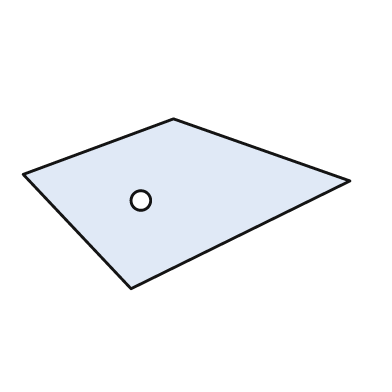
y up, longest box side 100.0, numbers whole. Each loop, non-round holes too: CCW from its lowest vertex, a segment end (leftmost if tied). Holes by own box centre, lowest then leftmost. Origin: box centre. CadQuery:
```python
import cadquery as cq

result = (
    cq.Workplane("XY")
    .moveTo(-17.0, -26.0)
    .lineTo(50.0, 7.0)
    .lineTo(-4.0, 26.0)
    .lineTo(-50.0, 9.0)
    .close()
    .moveTo(-14.0, 1.0)
    .circle(3.0)
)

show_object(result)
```